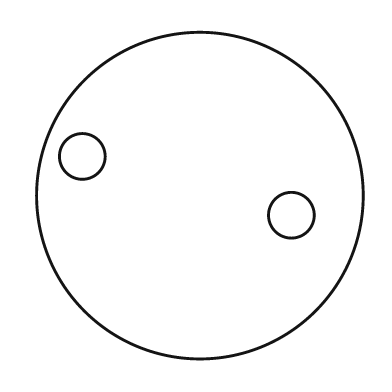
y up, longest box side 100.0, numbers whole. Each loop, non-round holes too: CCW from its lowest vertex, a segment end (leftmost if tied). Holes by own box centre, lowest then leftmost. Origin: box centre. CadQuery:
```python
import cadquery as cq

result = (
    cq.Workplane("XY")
    .moveTo(0.0, 0.0)
    .circle(50.0)
    .moveTo(28.0, -6.0)
    .circle(7.0)
    .moveTo(-36.0, 12.0)
    .circle(7.0)
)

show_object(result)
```